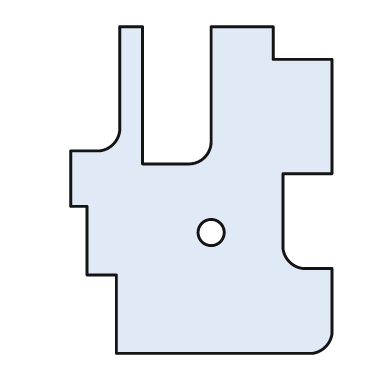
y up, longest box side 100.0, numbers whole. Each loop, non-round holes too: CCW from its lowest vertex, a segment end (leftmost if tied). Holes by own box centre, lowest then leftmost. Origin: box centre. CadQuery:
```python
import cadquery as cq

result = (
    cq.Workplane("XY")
    .moveTo(-26.0, -50.0)
    .lineTo(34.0, -50.0)
    .threePointArc((38.0, -48.0), (40.0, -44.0))
    .lineTo(40.0, -24.0)
    .lineTo(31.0, -24.0)
    .threePointArc((27.0, -22.0), (25.0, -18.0))
    .lineTo(25.0, 5.0)
    .lineTo(40.0, 5.0)
    .lineTo(40.0, 40.0)
    .lineTo(22.0, 40.0)
    .lineTo(22.0, 50.0)
    .lineTo(3.0, 50.0)
    .lineTo(3.0, 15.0)
    .threePointArc((1.0, 10.0), (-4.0, 8.0))
    .lineTo(-18.0, 8.0)
    .lineTo(-18.0, 50.0)
    .lineTo(-25.0, 50.0)
    .lineTo(-25.0, 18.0)
    .threePointArc((-27.0, 14.0), (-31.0, 12.0))
    .lineTo(-40.0, 12.0)
    .lineTo(-40.0, -5.0)
    .lineTo(-35.0, -5.0)
    .lineTo(-35.0, -26.0)
    .lineTo(-26.0, -26.0)
    .close()
    .moveTo(3.0, -13.0)
    .circle(4.0)
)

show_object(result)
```